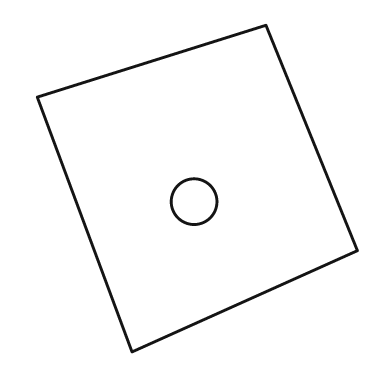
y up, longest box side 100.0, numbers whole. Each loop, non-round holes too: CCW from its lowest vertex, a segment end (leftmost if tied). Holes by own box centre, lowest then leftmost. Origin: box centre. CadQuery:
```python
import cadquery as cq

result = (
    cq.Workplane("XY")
    .moveTo(-20.0, -50.0)
    .lineTo(49.0, -19.0)
    .lineTo(21.0, 50.0)
    .lineTo(-49.0, 28.0)
    .close()
    .moveTo(-1.0, -4.0)
    .circle(7.0)
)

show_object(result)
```